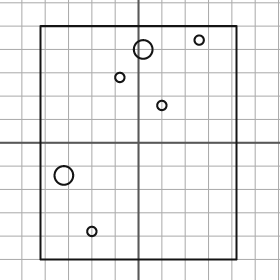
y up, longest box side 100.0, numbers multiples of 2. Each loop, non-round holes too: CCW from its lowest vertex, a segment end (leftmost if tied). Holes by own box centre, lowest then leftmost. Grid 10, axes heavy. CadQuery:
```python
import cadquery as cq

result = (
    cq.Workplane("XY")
    .moveTo(-42.0, -50.0)
    .lineTo(42.0, -50.0)
    .lineTo(42.0, 50.0)
    .lineTo(-42.0, 50.0)
    .close()
    .moveTo(-20.0, -38.0)
    .circle(2.0)
    .moveTo(-32.0, -14.0)
    .circle(4.0)
    .moveTo(10.0, 16.0)
    .circle(2.0)
    .moveTo(-8.0, 28.0)
    .circle(2.0)
    .moveTo(2.0, 40.0)
    .circle(4.0)
    .moveTo(26.0, 44.0)
    .circle(2.0)
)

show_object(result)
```